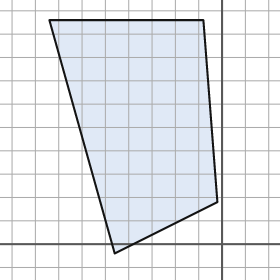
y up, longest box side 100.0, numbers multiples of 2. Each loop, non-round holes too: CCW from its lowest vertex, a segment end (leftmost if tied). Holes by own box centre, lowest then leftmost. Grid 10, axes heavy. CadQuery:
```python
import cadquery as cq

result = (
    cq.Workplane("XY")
    .moveTo(-46.0, -4.0)
    .lineTo(-2.0, 18.0)
    .lineTo(-8.0, 96.0)
    .lineTo(-74.0, 96.0)
    .close()
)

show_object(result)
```